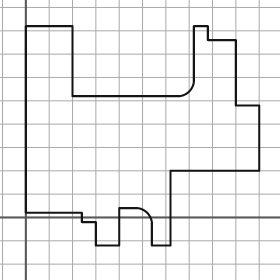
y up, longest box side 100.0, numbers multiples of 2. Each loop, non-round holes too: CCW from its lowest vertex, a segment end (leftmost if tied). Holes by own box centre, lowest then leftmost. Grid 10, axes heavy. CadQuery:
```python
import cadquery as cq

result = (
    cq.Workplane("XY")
    .moveTo(30.0, -12.0)
    .lineTo(40.0, -12.0)
    .lineTo(40.0, 4.0)
    .lineTo(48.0, 4.0)
    .threePointArc((52.0, 2.0), (54.0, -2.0))
    .lineTo(54.0, -12.0)
    .lineTo(62.0, -12.0)
    .lineTo(62.0, 20.0)
    .lineTo(100.0, 20.0)
    .lineTo(100.0, 48.0)
    .lineTo(90.0, 48.0)
    .lineTo(90.0, 76.0)
    .lineTo(78.0, 76.0)
    .lineTo(78.0, 82.0)
    .lineTo(72.0, 82.0)
    .lineTo(72.0, 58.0)
    .threePointArc((70.0, 54.0), (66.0, 52.0))
    .lineTo(20.0, 52.0)
    .lineTo(20.0, 82.0)
    .lineTo(0.0, 82.0)
    .lineTo(0.0, 2.0)
    .lineTo(24.0, 2.0)
    .lineTo(24.0, -2.0)
    .lineTo(30.0, -2.0)
    .close()
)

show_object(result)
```